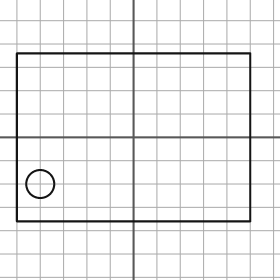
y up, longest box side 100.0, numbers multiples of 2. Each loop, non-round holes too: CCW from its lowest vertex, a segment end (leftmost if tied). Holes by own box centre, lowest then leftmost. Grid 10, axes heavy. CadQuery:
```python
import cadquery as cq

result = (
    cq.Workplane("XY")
    .moveTo(-50.0, -36.0)
    .lineTo(50.0, -36.0)
    .lineTo(50.0, 36.0)
    .lineTo(-50.0, 36.0)
    .close()
    .moveTo(-40.0, -20.0)
    .circle(6.0)
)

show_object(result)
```